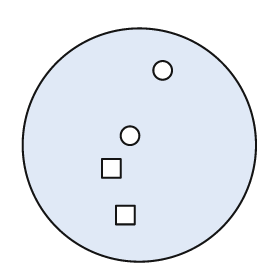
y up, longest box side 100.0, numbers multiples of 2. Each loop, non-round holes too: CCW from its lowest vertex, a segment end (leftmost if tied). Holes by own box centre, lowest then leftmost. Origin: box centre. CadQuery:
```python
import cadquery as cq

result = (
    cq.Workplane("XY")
    .moveTo(0.0, 0.0)
    .circle(50.0)
    .moveTo(-10.0, -34.0)
    .lineTo(-2.0, -34.0)
    .lineTo(-2.0, -26.0)
    .lineTo(-10.0, -26.0)
    .close()
    .moveTo(-16.0, -14.0)
    .lineTo(-8.0, -14.0)
    .lineTo(-8.0, -6.0)
    .lineTo(-16.0, -6.0)
    .close()
    .moveTo(-4.0, 4.0)
    .circle(4.0)
    .moveTo(10.0, 32.0)
    .circle(4.0)
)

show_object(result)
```